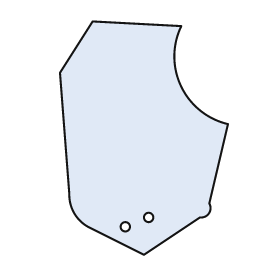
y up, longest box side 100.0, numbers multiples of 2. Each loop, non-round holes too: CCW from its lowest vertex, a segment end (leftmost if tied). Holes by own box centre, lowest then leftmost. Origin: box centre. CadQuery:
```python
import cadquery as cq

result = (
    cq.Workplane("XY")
    .moveTo(0.0, -50.0)
    .lineTo(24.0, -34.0)
    .threePointArc((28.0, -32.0), (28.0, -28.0))
    .lineTo(36.0, 6.0)
    .threePointArc((16.0, 22.0), (16.0, 48.0))
    .lineTo(-22.0, 50.0)
    .lineTo(-36.0, 28.0)
    .lineTo(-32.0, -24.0)
    .threePointArc((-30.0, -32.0), (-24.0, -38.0))
    .close()
    .moveTo(-8.0, -38.0)
    .circle(2.0)
    .moveTo(2.0, -34.0)
    .circle(2.0)
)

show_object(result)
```